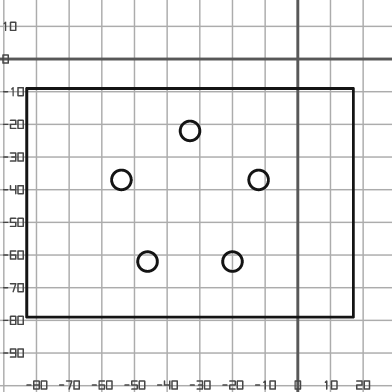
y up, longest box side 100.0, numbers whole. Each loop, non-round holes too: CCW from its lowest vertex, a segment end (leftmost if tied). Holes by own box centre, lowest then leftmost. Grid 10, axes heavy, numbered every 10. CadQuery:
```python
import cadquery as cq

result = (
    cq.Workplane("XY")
    .moveTo(-83.0, -79.0)
    .lineTo(17.0, -79.0)
    .lineTo(17.0, -9.0)
    .lineTo(-83.0, -9.0)
    .close()
    .moveTo(-46.0, -62.0)
    .circle(3.0)
    .moveTo(-20.0, -62.0)
    .circle(3.0)
    .moveTo(-54.0, -37.0)
    .circle(3.0)
    .moveTo(-12.0, -37.0)
    .circle(3.0)
    .moveTo(-33.0, -22.0)
    .circle(3.0)
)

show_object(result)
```